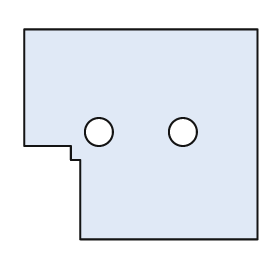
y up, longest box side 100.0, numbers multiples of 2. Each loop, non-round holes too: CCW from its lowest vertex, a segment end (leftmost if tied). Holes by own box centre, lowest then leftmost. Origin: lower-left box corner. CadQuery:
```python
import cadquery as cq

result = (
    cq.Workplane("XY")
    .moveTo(24.0, 0.0)
    .lineTo(100.0, 0.0)
    .lineTo(100.0, 90.0)
    .lineTo(0.0, 90.0)
    .lineTo(0.0, 40.0)
    .lineTo(20.0, 40.0)
    .lineTo(20.0, 34.0)
    .lineTo(24.0, 34.0)
    .close()
    .moveTo(32.0, 46.0)
    .circle(6.0)
    .moveTo(68.0, 46.0)
    .circle(6.0)
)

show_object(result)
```